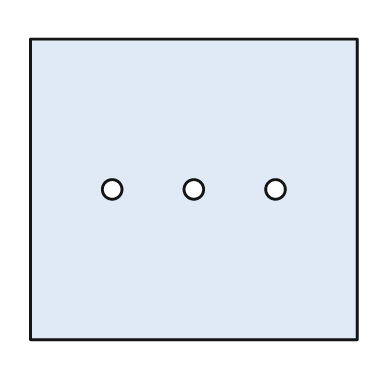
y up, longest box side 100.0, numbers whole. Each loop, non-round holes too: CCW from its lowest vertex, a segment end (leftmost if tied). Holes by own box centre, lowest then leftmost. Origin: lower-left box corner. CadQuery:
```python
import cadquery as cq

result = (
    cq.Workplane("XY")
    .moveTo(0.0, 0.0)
    .lineTo(100.0, 0.0)
    .lineTo(100.0, 92.0)
    .lineTo(0.0, 92.0)
    .close()
    .moveTo(25.0, 46.0)
    .circle(3.0)
    .moveTo(50.0, 46.0)
    .circle(3.0)
    .moveTo(75.0, 46.0)
    .circle(3.0)
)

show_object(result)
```